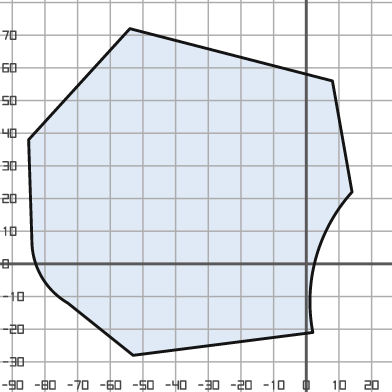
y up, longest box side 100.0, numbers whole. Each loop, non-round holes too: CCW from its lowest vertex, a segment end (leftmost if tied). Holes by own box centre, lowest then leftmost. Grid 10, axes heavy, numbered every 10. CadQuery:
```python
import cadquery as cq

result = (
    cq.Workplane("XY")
    .moveTo(-53.0, -28.0)
    .lineTo(2.0, -21.0)
    .threePointArc((3.0, 2.0), (14.0, 22.0))
    .lineTo(8.0, 56.0)
    .lineTo(-54.0, 72.0)
    .lineTo(-85.0, 38.0)
    .lineTo(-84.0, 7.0)
    .threePointArc((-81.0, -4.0), (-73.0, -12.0))
    .close()
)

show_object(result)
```